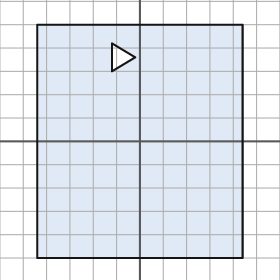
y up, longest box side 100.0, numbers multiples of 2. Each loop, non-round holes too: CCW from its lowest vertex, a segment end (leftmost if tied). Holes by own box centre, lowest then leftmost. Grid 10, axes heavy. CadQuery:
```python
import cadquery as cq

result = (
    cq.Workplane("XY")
    .moveTo(-44.0, -50.0)
    .lineTo(44.0, -50.0)
    .lineTo(44.0, 50.0)
    .lineTo(-44.0, 50.0)
    .close()
    .moveTo(-12.0, 30.0)
    .lineTo(-2.0, 36.0)
    .lineTo(-12.0, 42.0)
    .close()
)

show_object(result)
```